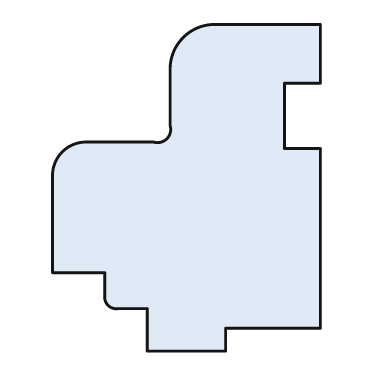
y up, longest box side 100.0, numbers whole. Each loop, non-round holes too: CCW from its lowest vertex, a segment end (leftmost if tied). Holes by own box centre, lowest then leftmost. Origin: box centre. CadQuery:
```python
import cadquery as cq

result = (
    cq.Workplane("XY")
    .moveTo(-12.0, -50.0)
    .lineTo(12.0, -50.0)
    .lineTo(12.0, -43.0)
    .lineTo(41.0, -43.0)
    .lineTo(41.0, 12.0)
    .lineTo(30.0, 12.0)
    .lineTo(30.0, 32.0)
    .lineTo(41.0, 32.0)
    .lineTo(41.0, 50.0)
    .lineTo(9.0, 50.0)
    .threePointArc((-1.0, 46.0), (-5.0, 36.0))
    .lineTo(-5.0, 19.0)
    .threePointArc((-6.0, 15.0), (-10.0, 14.0))
    .lineTo(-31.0, 14.0)
    .threePointArc((-38.0, 11.0), (-41.0, 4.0))
    .lineTo(-41.0, -26.0)
    .lineTo(-25.0, -26.0)
    .lineTo(-25.0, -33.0)
    .threePointArc((-24.0, -36.0), (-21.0, -37.0))
    .lineTo(-12.0, -37.0)
    .close()
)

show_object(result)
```